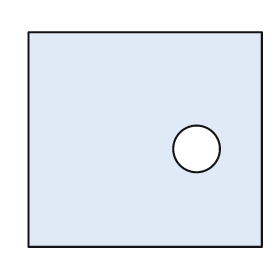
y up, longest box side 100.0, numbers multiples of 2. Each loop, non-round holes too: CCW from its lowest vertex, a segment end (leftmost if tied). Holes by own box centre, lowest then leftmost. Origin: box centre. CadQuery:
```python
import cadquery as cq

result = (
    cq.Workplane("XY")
    .moveTo(-50.0, -46.0)
    .lineTo(50.0, -46.0)
    .lineTo(50.0, 46.0)
    .lineTo(-50.0, 46.0)
    .close()
    .moveTo(22.0, -4.0)
    .circle(10.0)
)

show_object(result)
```